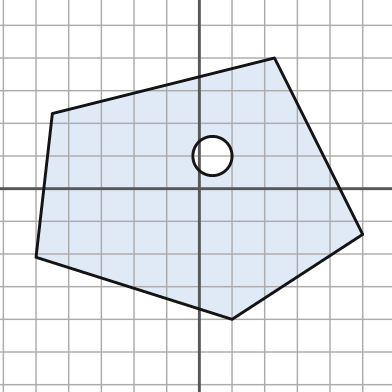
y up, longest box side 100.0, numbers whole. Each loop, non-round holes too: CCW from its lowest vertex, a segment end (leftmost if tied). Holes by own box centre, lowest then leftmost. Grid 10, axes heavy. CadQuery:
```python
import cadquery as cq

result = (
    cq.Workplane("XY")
    .moveTo(10.0, -40.0)
    .lineTo(50.0, -14.0)
    .lineTo(23.0, 40.0)
    .lineTo(-45.0, 23.0)
    .lineTo(-50.0, -21.0)
    .close()
    .moveTo(4.0, 10.0)
    .circle(6.0)
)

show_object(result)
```